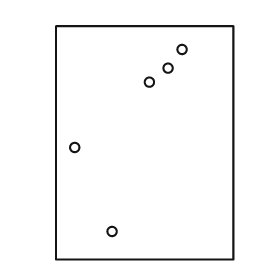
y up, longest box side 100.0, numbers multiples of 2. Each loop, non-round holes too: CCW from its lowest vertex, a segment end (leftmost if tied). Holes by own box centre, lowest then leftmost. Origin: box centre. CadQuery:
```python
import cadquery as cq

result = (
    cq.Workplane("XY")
    .moveTo(-38.0, -50.0)
    .lineTo(38.0, -50.0)
    .lineTo(38.0, 50.0)
    .lineTo(-38.0, 50.0)
    .close()
    .moveTo(-14.0, -38.0)
    .circle(2.0)
    .moveTo(-30.0, -2.0)
    .circle(2.0)
    .moveTo(2.0, 26.0)
    .circle(2.0)
    .moveTo(10.0, 32.0)
    .circle(2.0)
    .moveTo(16.0, 40.0)
    .circle(2.0)
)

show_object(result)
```